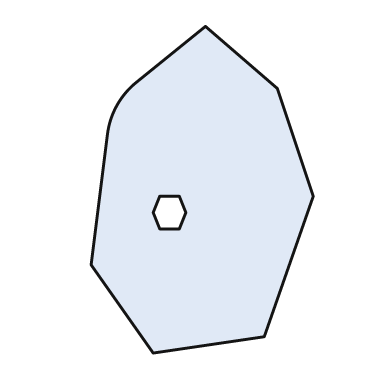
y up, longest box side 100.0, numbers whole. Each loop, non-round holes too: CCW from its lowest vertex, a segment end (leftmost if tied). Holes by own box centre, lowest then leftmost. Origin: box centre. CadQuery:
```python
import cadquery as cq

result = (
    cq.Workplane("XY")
    .moveTo(-15.0, -50.0)
    .lineTo(19.0, -45.0)
    .lineTo(34.0, -2.0)
    .lineTo(23.0, 31.0)
    .lineTo(1.0, 50.0)
    .lineTo(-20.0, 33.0)
    .threePointArc((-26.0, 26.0), (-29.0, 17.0))
    .lineTo(-34.0, -23.0)
    .close()
    .moveTo(-13.0, -12.0)
    .lineTo(-7.0, -12.0)
    .lineTo(-5.0, -7.0)
    .lineTo(-7.0, -2.0)
    .lineTo(-13.0, -2.0)
    .lineTo(-15.0, -7.0)
    .close()
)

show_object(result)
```